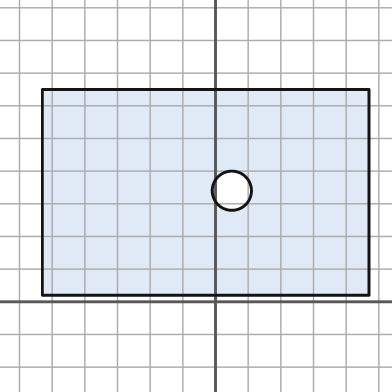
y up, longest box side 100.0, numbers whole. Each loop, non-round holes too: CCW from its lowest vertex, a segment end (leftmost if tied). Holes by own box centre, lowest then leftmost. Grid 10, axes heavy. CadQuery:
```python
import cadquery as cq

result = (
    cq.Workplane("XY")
    .moveTo(-53.0, 2.0)
    .lineTo(47.0, 2.0)
    .lineTo(47.0, 65.0)
    .lineTo(-53.0, 65.0)
    .close()
    .moveTo(5.0, 34.0)
    .circle(6.0)
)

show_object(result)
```